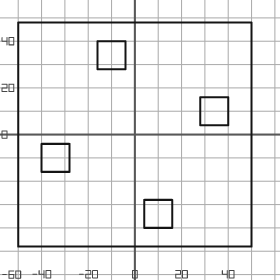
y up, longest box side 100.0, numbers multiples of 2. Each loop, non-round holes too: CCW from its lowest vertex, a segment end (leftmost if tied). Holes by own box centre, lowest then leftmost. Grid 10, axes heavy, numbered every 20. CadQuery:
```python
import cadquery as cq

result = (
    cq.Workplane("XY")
    .moveTo(-50.0, -48.0)
    .lineTo(50.0, -48.0)
    .lineTo(50.0, 48.0)
    .lineTo(-50.0, 48.0)
    .close()
    .moveTo(4.0, -40.0)
    .lineTo(16.0, -40.0)
    .lineTo(16.0, -28.0)
    .lineTo(4.0, -28.0)
    .close()
    .moveTo(-40.0, -16.0)
    .lineTo(-28.0, -16.0)
    .lineTo(-28.0, -4.0)
    .lineTo(-40.0, -4.0)
    .close()
    .moveTo(28.0, 4.0)
    .lineTo(40.0, 4.0)
    .lineTo(40.0, 16.0)
    .lineTo(28.0, 16.0)
    .close()
    .moveTo(-16.0, 28.0)
    .lineTo(-4.0, 28.0)
    .lineTo(-4.0, 40.0)
    .lineTo(-16.0, 40.0)
    .close()
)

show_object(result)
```